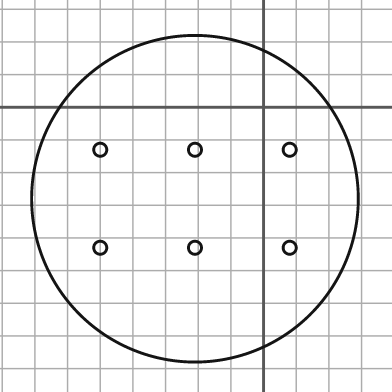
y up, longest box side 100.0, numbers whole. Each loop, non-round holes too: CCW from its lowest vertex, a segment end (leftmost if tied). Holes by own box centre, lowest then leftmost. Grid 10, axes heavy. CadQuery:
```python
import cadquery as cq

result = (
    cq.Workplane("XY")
    .moveTo(-21.0, -28.0)
    .circle(50.0)
    .moveTo(-50.0, -43.0)
    .circle(2.0)
    .moveTo(-21.0, -43.0)
    .circle(2.0)
    .moveTo(8.0, -43.0)
    .circle(2.0)
    .moveTo(-50.0, -13.0)
    .circle(2.0)
    .moveTo(-21.0, -13.0)
    .circle(2.0)
    .moveTo(8.0, -13.0)
    .circle(2.0)
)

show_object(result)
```